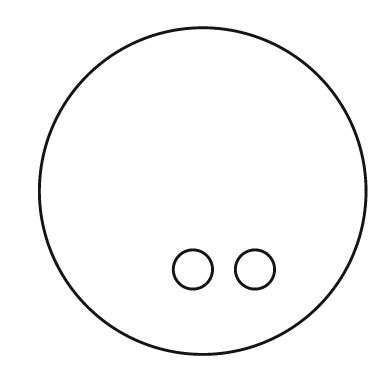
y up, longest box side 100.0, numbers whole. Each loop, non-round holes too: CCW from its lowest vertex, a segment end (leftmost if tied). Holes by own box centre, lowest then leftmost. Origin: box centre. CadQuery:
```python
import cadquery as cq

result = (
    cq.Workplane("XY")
    .moveTo(0.0, 0.0)
    .circle(50.0)
    .moveTo(-3.0, -24.0)
    .circle(6.0)
    .moveTo(16.0, -24.0)
    .circle(6.0)
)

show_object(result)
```